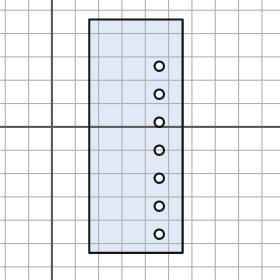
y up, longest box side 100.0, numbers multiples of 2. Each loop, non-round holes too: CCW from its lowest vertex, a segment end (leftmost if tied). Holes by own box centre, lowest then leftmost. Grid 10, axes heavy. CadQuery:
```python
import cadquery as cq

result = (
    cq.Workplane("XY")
    .moveTo(16.0, -54.0)
    .lineTo(56.0, -54.0)
    .lineTo(56.0, 46.0)
    .lineTo(16.0, 46.0)
    .close()
    .moveTo(46.0, -46.0)
    .circle(2.0)
    .moveTo(46.0, -34.0)
    .circle(2.0)
    .moveTo(46.0, -22.0)
    .circle(2.0)
    .moveTo(46.0, -10.0)
    .circle(2.0)
    .moveTo(46.0, 2.0)
    .circle(2.0)
    .moveTo(46.0, 14.0)
    .circle(2.0)
    .moveTo(46.0, 26.0)
    .circle(2.0)
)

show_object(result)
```